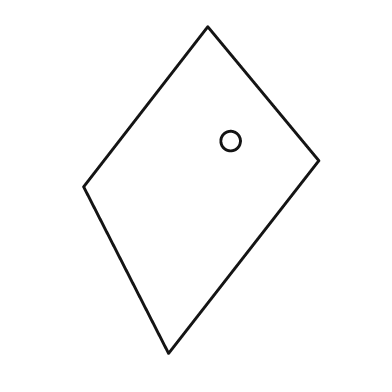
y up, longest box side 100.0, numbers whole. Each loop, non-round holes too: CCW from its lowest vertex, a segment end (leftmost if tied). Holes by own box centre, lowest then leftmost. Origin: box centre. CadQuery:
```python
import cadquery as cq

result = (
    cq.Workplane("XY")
    .moveTo(-10.0, -50.0)
    .lineTo(36.0, 9.0)
    .lineTo(2.0, 50.0)
    .lineTo(-36.0, 1.0)
    .close()
    .moveTo(9.0, 15.0)
    .circle(3.0)
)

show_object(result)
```